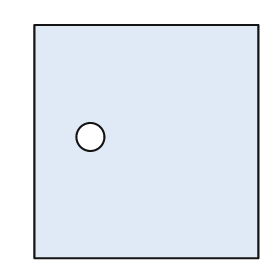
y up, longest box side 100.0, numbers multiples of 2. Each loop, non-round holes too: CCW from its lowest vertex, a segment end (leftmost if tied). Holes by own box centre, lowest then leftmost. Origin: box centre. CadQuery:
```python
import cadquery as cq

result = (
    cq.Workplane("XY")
    .moveTo(-48.0, -50.0)
    .lineTo(48.0, -50.0)
    .lineTo(48.0, 50.0)
    .lineTo(-48.0, 50.0)
    .close()
    .moveTo(-24.0, 2.0)
    .circle(6.0)
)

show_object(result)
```